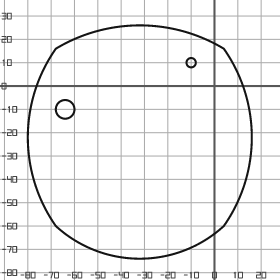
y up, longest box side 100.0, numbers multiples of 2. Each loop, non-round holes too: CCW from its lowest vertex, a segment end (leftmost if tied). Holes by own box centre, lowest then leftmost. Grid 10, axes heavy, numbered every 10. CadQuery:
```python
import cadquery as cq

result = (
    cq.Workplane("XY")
    .moveTo(-68.0, -60.0)
    .threePointArc((-32.0, -74.0), (4.0, -60.0))
    .threePointArc((16.0, -22.0), (4.0, 16.0))
    .threePointArc((-32.0, 26.0), (-68.0, 16.0))
    .threePointArc((-80.0, -22.0), (-68.0, -60.0))
    .close()
    .moveTo(-64.0, -10.0)
    .circle(4.0)
    .moveTo(-10.0, 10.0)
    .circle(2.0)
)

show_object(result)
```